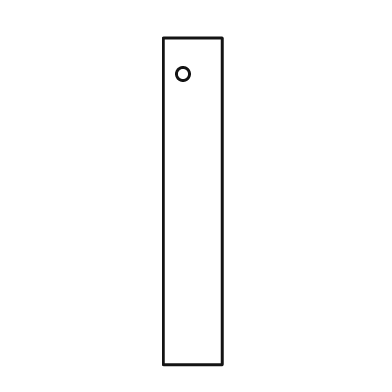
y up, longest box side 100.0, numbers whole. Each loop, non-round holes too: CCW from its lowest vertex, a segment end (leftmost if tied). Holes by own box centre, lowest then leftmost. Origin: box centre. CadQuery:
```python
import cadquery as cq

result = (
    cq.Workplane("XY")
    .moveTo(-9.0, -50.0)
    .lineTo(9.0, -50.0)
    .lineTo(9.0, 50.0)
    .lineTo(-9.0, 50.0)
    .close()
    .moveTo(-3.0, 39.0)
    .circle(2.0)
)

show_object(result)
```